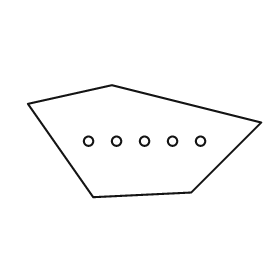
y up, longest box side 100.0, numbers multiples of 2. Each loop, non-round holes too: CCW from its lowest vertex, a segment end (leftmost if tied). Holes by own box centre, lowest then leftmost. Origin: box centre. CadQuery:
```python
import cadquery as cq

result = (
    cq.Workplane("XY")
    .moveTo(-22.0, -24.0)
    .lineTo(20.0, -22.0)
    .lineTo(50.0, 8.0)
    .lineTo(-14.0, 24.0)
    .lineTo(-50.0, 16.0)
    .close()
    .moveTo(-24.0, 0.0)
    .circle(2.0)
    .moveTo(-12.0, 0.0)
    .circle(2.0)
    .moveTo(0.0, 0.0)
    .circle(2.0)
    .moveTo(12.0, 0.0)
    .circle(2.0)
    .moveTo(24.0, 0.0)
    .circle(2.0)
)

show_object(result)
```